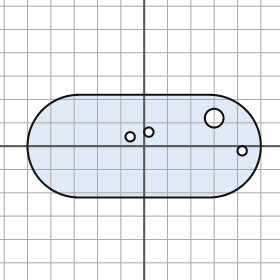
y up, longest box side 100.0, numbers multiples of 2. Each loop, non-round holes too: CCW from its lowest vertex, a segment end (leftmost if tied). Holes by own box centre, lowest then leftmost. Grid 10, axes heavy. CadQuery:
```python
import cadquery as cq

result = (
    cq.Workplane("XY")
    .moveTo(-28.0, -22.0)
    .lineTo(28.0, -22.0)
    .threePointArc((50.0, 0.0), (28.0, 22.0))
    .lineTo(-28.0, 22.0)
    .threePointArc((-50.0, 0.0), (-28.0, -22.0))
    .close()
    .moveTo(42.0, -2.0)
    .circle(2.0)
    .moveTo(-6.0, 4.0)
    .circle(2.0)
    .moveTo(2.0, 6.0)
    .circle(2.0)
    .moveTo(30.0, 12.0)
    .circle(4.0)
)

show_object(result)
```